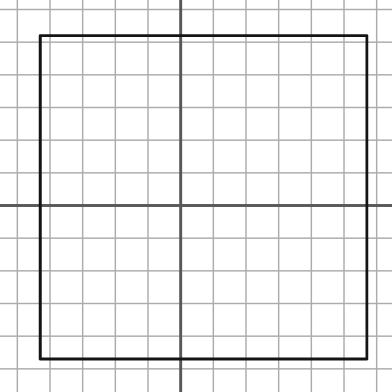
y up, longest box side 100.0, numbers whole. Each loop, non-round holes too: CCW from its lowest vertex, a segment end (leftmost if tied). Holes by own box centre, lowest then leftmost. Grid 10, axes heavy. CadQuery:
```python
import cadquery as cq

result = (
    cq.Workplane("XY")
    .moveTo(-43.0, -47.0)
    .lineTo(57.0, -47.0)
    .lineTo(57.0, 52.0)
    .lineTo(-43.0, 52.0)
    .close()
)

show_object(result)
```